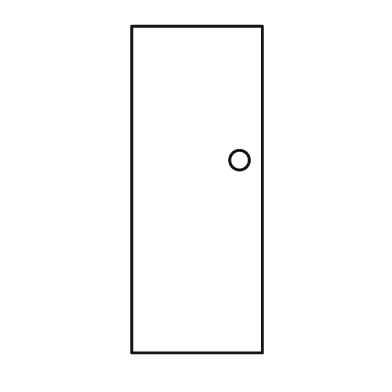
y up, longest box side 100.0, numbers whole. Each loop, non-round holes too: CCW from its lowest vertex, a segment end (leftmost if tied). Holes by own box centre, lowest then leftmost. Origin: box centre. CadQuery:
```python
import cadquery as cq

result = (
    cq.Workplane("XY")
    .moveTo(-20.0, -50.0)
    .lineTo(20.0, -50.0)
    .lineTo(20.0, 50.0)
    .lineTo(-20.0, 50.0)
    .close()
    .moveTo(13.0, 9.0)
    .circle(3.0)
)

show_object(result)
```